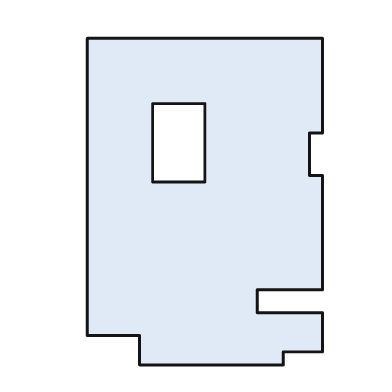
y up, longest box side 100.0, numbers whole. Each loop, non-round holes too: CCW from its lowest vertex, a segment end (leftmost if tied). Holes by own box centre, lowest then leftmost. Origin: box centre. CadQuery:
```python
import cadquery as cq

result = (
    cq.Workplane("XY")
    .moveTo(-20.0, -50.0)
    .lineTo(24.0, -50.0)
    .lineTo(24.0, -46.0)
    .lineTo(36.0, -46.0)
    .lineTo(36.0, -34.0)
    .lineTo(16.0, -34.0)
    .lineTo(16.0, -27.0)
    .lineTo(36.0, -27.0)
    .lineTo(36.0, 8.0)
    .lineTo(32.0, 8.0)
    .lineTo(32.0, 21.0)
    .lineTo(36.0, 21.0)
    .lineTo(36.0, 50.0)
    .lineTo(-36.0, 50.0)
    .lineTo(-36.0, -41.0)
    .lineTo(-20.0, -41.0)
    .close()
    .moveTo(-16.0, 6.0)
    .lineTo(0.0, 6.0)
    .lineTo(0.0, 30.0)
    .lineTo(-16.0, 30.0)
    .close()
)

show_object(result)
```